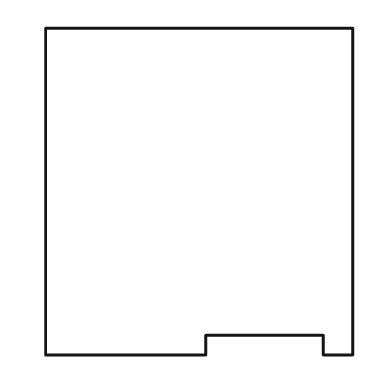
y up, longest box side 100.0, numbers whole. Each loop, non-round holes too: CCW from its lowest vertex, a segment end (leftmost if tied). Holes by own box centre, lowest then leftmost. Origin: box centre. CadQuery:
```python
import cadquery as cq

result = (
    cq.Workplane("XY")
    .moveTo(-47.0, -50.0)
    .lineTo(2.0, -50.0)
    .lineTo(2.0, -44.0)
    .lineTo(38.0, -44.0)
    .lineTo(38.0, -50.0)
    .lineTo(47.0, -50.0)
    .lineTo(47.0, 50.0)
    .lineTo(-47.0, 50.0)
    .close()
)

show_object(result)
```